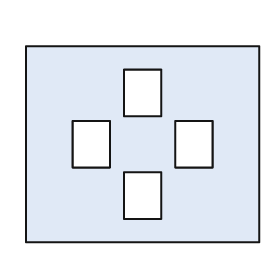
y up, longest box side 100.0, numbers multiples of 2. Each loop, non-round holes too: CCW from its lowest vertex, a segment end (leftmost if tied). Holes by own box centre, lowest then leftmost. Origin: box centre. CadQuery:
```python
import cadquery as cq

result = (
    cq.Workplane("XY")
    .moveTo(-50.0, -42.0)
    .lineTo(50.0, -42.0)
    .lineTo(50.0, 42.0)
    .lineTo(-50.0, 42.0)
    .close()
    .moveTo(-8.0, -32.0)
    .lineTo(8.0, -32.0)
    .lineTo(8.0, -12.0)
    .lineTo(-8.0, -12.0)
    .close()
    .moveTo(-30.0, -10.0)
    .lineTo(-14.0, -10.0)
    .lineTo(-14.0, 10.0)
    .lineTo(-30.0, 10.0)
    .close()
    .moveTo(14.0, -10.0)
    .lineTo(30.0, -10.0)
    .lineTo(30.0, 10.0)
    .lineTo(14.0, 10.0)
    .close()
    .moveTo(-8.0, 12.0)
    .lineTo(8.0, 12.0)
    .lineTo(8.0, 32.0)
    .lineTo(-8.0, 32.0)
    .close()
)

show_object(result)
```